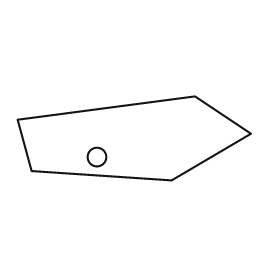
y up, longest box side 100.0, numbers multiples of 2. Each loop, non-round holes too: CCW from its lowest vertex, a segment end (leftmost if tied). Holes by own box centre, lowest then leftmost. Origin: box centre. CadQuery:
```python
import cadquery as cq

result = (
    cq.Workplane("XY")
    .moveTo(16.0, -18.0)
    .lineTo(50.0, 2.0)
    .lineTo(26.0, 18.0)
    .lineTo(-50.0, 8.0)
    .lineTo(-44.0, -14.0)
    .close()
    .moveTo(-16.0, -8.0)
    .circle(4.0)
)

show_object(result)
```